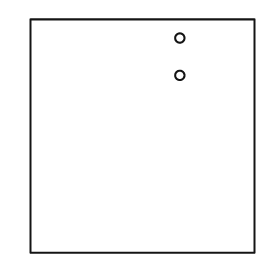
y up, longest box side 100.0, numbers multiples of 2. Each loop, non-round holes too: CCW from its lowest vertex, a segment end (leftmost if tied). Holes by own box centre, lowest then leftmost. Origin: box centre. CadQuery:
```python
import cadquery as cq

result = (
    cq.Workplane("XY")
    .moveTo(-48.0, -50.0)
    .lineTo(48.0, -50.0)
    .lineTo(48.0, 50.0)
    .lineTo(-48.0, 50.0)
    .close()
    .moveTo(16.0, 26.0)
    .circle(2.0)
    .moveTo(16.0, 42.0)
    .circle(2.0)
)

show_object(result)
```